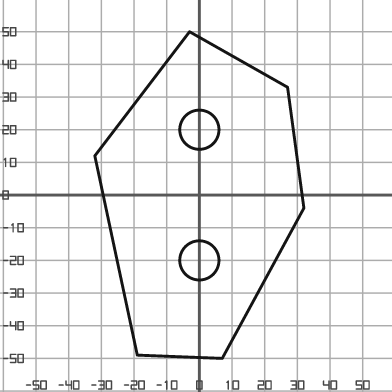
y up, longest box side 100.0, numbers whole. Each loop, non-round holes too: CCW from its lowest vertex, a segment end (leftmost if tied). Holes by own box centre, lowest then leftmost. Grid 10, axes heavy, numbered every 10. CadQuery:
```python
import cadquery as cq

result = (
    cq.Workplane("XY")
    .moveTo(7.0, -50.0)
    .lineTo(32.0, -4.0)
    .lineTo(27.0, 33.0)
    .lineTo(-3.0, 50.0)
    .lineTo(-32.0, 12.0)
    .lineTo(-19.0, -49.0)
    .close()
    .moveTo(0.0, -20.0)
    .circle(6.0)
    .moveTo(0.0, 20.0)
    .circle(6.0)
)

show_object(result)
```